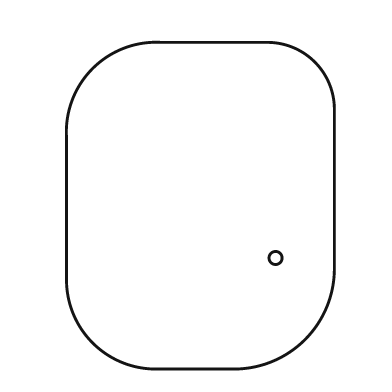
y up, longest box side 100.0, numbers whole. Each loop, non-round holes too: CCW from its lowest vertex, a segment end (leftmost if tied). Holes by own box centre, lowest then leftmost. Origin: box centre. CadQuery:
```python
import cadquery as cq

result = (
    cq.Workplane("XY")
    .moveTo(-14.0, -50.0)
    .lineTo(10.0, -50.0)
    .threePointArc((32.0, -41.0), (41.0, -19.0))
    .lineTo(41.0, 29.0)
    .threePointArc((35.0, 44.0), (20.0, 50.0))
    .lineTo(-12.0, 50.0)
    .threePointArc((-33.0, 42.0), (-41.0, 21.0))
    .lineTo(-41.0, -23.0)
    .threePointArc((-33.0, -42.0), (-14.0, -50.0))
    .close()
    .moveTo(23.0, -16.0)
    .circle(2.0)
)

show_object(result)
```